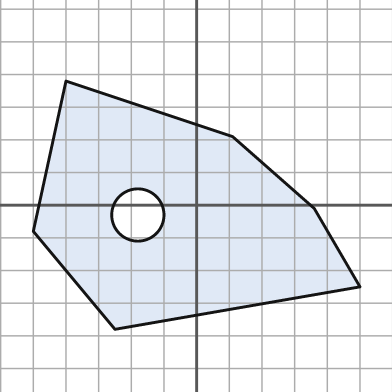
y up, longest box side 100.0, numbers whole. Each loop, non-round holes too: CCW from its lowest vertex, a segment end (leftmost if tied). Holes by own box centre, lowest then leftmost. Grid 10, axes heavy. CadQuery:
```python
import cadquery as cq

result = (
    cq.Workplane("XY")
    .moveTo(-25.0, -38.0)
    .lineTo(50.0, -25.0)
    .lineTo(36.0, -1.0)
    .lineTo(11.0, 21.0)
    .lineTo(-40.0, 38.0)
    .lineTo(-50.0, -8.0)
    .close()
    .moveTo(-18.0, -3.0)
    .circle(8.0)
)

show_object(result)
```